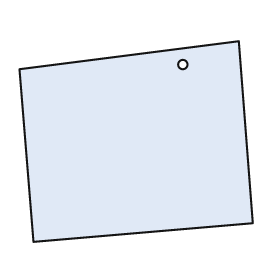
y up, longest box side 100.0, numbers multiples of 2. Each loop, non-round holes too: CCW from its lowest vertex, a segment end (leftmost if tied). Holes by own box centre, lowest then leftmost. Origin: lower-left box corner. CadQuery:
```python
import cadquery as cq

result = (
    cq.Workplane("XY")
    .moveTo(6.0, 0.0)
    .lineTo(100.0, 8.0)
    .lineTo(94.0, 86.0)
    .lineTo(0.0, 74.0)
    .close()
    .moveTo(70.0, 76.0)
    .circle(2.0)
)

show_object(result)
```